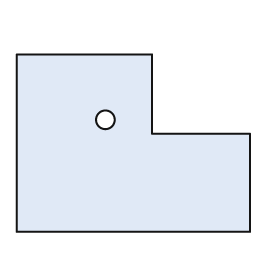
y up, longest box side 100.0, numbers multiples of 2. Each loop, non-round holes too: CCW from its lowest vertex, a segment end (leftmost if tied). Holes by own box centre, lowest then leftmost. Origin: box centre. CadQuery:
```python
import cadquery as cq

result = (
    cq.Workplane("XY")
    .moveTo(-50.0, -38.0)
    .lineTo(50.0, -38.0)
    .lineTo(50.0, 4.0)
    .lineTo(8.0, 4.0)
    .lineTo(8.0, 38.0)
    .lineTo(-50.0, 38.0)
    .close()
    .moveTo(-12.0, 10.0)
    .circle(4.0)
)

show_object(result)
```